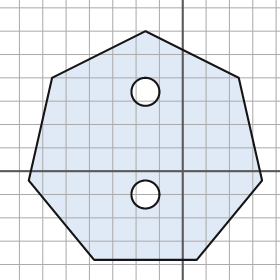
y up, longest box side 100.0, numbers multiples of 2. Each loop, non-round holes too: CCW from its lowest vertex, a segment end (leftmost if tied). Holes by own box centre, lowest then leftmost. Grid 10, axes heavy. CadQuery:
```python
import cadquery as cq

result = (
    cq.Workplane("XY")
    .moveTo(-38.0, -38.0)
    .lineTo(6.0, -38.0)
    .lineTo(34.0, -4.0)
    .lineTo(24.0, 40.0)
    .lineTo(-16.0, 60.0)
    .lineTo(-56.0, 40.0)
    .lineTo(-66.0, -4.0)
    .close()
    .moveTo(-16.0, -10.0)
    .circle(6.0)
    .moveTo(-16.0, 34.0)
    .circle(6.0)
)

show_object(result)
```